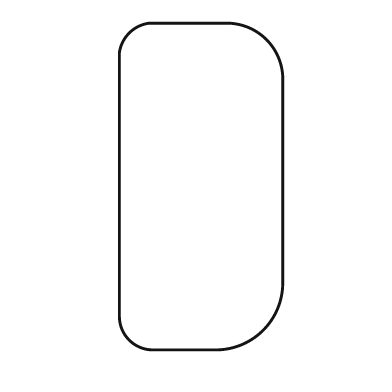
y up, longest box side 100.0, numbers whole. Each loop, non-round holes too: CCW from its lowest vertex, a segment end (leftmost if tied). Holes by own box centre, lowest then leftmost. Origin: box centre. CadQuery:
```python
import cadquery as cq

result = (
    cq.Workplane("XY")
    .moveTo(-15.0, -50.0)
    .lineTo(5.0, -50.0)
    .threePointArc((19.0, -44.0), (25.0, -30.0))
    .lineTo(25.0, 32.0)
    .threePointArc((20.0, 45.0), (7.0, 50.0))
    .lineTo(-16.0, 50.0)
    .threePointArc((-22.0, 47.0), (-25.0, 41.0))
    .lineTo(-25.0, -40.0)
    .threePointArc((-22.0, -47.0), (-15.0, -50.0))
    .close()
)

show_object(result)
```